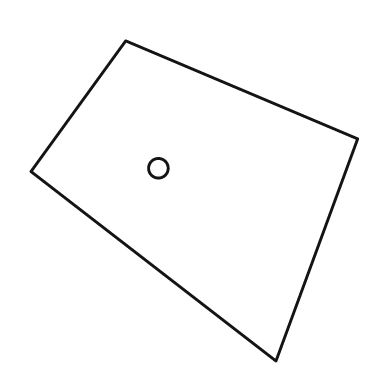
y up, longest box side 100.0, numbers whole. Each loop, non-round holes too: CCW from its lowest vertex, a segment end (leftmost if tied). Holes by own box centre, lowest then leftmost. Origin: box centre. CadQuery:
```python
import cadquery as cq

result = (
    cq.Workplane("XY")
    .moveTo(25.0, -49.0)
    .lineTo(50.0, 19.0)
    .lineTo(-21.0, 49.0)
    .lineTo(-50.0, 9.0)
    .close()
    .moveTo(-11.0, 10.0)
    .circle(3.0)
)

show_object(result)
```